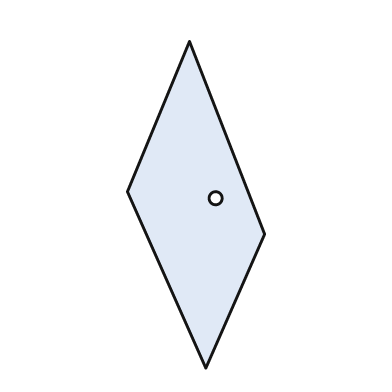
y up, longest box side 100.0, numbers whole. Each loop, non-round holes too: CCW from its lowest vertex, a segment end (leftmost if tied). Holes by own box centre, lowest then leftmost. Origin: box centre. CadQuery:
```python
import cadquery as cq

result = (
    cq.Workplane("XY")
    .moveTo(3.0, -50.0)
    .lineTo(21.0, -9.0)
    .lineTo(-2.0, 50.0)
    .lineTo(-21.0, 4.0)
    .close()
    .moveTo(6.0, 2.0)
    .circle(2.0)
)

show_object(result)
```